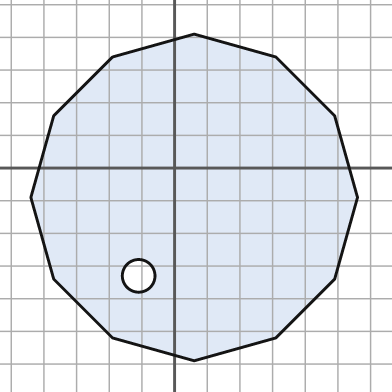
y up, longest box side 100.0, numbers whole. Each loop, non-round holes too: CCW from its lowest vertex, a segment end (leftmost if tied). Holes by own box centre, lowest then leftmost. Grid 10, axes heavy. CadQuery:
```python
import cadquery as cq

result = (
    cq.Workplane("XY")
    .moveTo(6.0, -59.0)
    .lineTo(31.0, -52.0)
    .lineTo(49.0, -34.0)
    .lineTo(56.0, -9.0)
    .lineTo(49.0, 16.0)
    .lineTo(31.0, 34.0)
    .lineTo(6.0, 41.0)
    .lineTo(-19.0, 34.0)
    .lineTo(-37.0, 16.0)
    .lineTo(-44.0, -9.0)
    .lineTo(-37.0, -34.0)
    .lineTo(-19.0, -52.0)
    .close()
    .moveTo(-11.0, -33.0)
    .circle(5.0)
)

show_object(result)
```